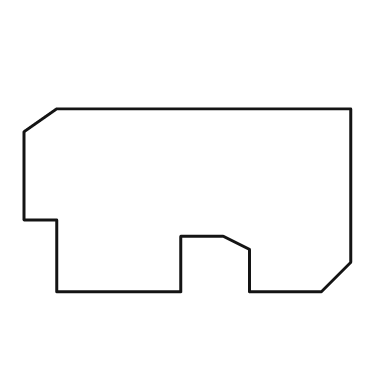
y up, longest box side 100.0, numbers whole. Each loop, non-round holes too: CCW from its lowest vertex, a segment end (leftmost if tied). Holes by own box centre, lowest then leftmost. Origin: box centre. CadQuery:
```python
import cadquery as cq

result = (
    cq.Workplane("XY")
    .moveTo(-40.0, -28.0)
    .lineTo(-2.0, -28.0)
    .lineTo(-2.0, -11.0)
    .lineTo(11.0, -11.0)
    .lineTo(19.0, -15.0)
    .lineTo(19.0, -28.0)
    .lineTo(41.0, -28.0)
    .lineTo(50.0, -19.0)
    .lineTo(50.0, 28.0)
    .lineTo(-40.0, 28.0)
    .lineTo(-50.0, 21.0)
    .lineTo(-50.0, -6.0)
    .lineTo(-40.0, -6.0)
    .close()
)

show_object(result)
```